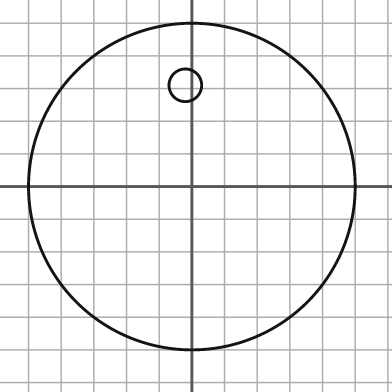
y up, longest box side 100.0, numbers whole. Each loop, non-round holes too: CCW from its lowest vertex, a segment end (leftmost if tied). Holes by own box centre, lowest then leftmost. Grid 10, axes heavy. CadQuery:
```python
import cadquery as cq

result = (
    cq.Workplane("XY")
    .moveTo(0.0, 0.0)
    .circle(50.0)
    .moveTo(-2.0, 31.0)
    .circle(5.0)
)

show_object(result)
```